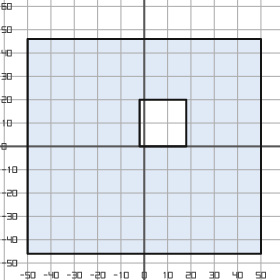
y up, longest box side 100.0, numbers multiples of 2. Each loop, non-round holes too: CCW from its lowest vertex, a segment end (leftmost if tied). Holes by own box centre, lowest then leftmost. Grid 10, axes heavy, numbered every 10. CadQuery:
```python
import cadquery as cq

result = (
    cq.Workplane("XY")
    .moveTo(-50.0, -46.0)
    .lineTo(50.0, -46.0)
    .lineTo(50.0, 46.0)
    .lineTo(-50.0, 46.0)
    .close()
    .moveTo(-2.0, 0.0)
    .lineTo(18.0, 0.0)
    .lineTo(18.0, 20.0)
    .lineTo(-2.0, 20.0)
    .close()
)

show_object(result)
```